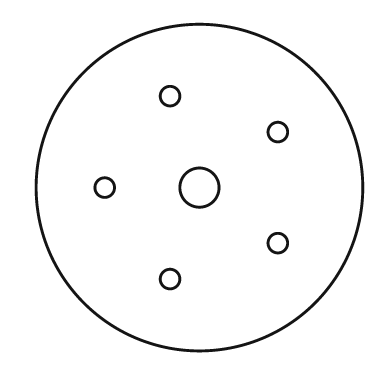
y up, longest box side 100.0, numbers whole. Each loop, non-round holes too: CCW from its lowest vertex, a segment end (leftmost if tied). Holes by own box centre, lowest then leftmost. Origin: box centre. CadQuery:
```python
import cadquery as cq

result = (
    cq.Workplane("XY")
    .moveTo(0.0, 0.0)
    .circle(50.0)
    .moveTo(-9.0, -28.0)
    .circle(3.0)
    .moveTo(24.0, -17.0)
    .circle(3.0)
    .moveTo(-29.0, 0.0)
    .circle(3.0)
    .moveTo(0.0, 0.0)
    .circle(6.0)
    .moveTo(24.0, 17.0)
    .circle(3.0)
    .moveTo(-9.0, 28.0)
    .circle(3.0)
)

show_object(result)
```